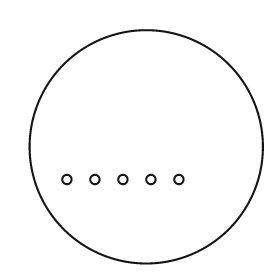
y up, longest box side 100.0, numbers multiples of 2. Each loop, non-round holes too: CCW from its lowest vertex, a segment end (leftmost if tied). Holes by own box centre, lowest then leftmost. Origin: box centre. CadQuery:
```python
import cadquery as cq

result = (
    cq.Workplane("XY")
    .moveTo(0.0, 0.0)
    .circle(50.0)
    .moveTo(-34.0, -14.0)
    .circle(2.0)
    .moveTo(-22.0, -14.0)
    .circle(2.0)
    .moveTo(-10.0, -14.0)
    .circle(2.0)
    .moveTo(2.0, -14.0)
    .circle(2.0)
    .moveTo(14.0, -14.0)
    .circle(2.0)
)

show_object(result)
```